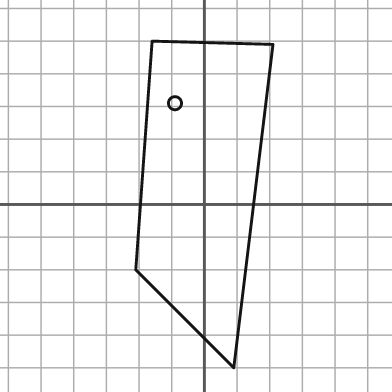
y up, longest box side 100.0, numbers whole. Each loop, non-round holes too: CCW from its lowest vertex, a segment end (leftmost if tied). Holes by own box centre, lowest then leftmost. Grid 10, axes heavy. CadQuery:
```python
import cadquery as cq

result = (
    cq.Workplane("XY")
    .moveTo(9.0, -50.0)
    .lineTo(21.0, 49.0)
    .lineTo(-16.0, 50.0)
    .lineTo(-21.0, -20.0)
    .close()
    .moveTo(-9.0, 31.0)
    .circle(2.0)
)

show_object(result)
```